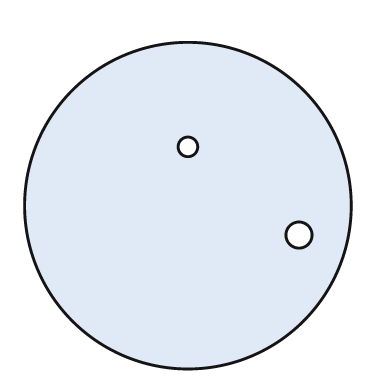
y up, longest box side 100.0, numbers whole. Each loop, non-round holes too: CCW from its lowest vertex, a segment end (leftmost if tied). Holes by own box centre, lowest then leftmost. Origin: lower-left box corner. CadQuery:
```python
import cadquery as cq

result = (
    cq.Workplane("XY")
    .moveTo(50.0, 50.0)
    .circle(50.0)
    .moveTo(84.0, 41.0)
    .circle(4.0)
    .moveTo(50.0, 68.0)
    .circle(3.0)
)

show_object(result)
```